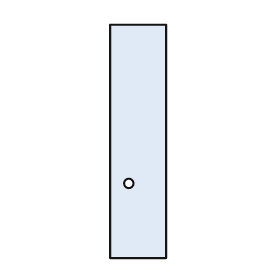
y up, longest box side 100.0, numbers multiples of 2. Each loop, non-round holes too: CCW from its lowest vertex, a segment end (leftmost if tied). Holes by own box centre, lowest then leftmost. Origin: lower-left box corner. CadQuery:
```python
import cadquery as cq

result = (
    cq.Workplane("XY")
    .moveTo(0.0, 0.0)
    .lineTo(24.0, 0.0)
    .lineTo(24.0, 100.0)
    .lineTo(0.0, 100.0)
    .close()
    .moveTo(8.0, 32.0)
    .circle(2.0)
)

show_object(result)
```